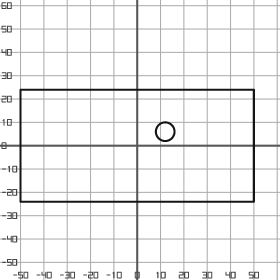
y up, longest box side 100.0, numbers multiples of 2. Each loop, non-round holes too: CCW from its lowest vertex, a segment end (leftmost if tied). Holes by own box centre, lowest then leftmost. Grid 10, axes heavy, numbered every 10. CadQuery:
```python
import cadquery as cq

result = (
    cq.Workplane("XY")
    .moveTo(-50.0, -24.0)
    .lineTo(50.0, -24.0)
    .lineTo(50.0, 24.0)
    .lineTo(-50.0, 24.0)
    .close()
    .moveTo(12.0, 6.0)
    .circle(4.0)
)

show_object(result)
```